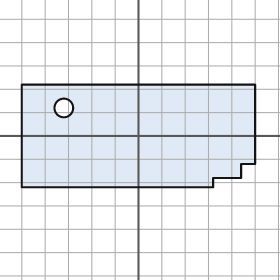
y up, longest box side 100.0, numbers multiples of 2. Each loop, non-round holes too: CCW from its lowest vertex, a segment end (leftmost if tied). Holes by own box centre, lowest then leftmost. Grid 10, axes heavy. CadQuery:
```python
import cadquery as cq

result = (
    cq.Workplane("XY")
    .moveTo(-50.0, -22.0)
    .lineTo(32.0, -22.0)
    .lineTo(32.0, -18.0)
    .lineTo(44.0, -18.0)
    .lineTo(44.0, -12.0)
    .lineTo(50.0, -12.0)
    .lineTo(50.0, 22.0)
    .lineTo(-50.0, 22.0)
    .close()
    .moveTo(-32.0, 12.0)
    .circle(4.0)
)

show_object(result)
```